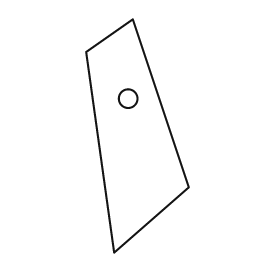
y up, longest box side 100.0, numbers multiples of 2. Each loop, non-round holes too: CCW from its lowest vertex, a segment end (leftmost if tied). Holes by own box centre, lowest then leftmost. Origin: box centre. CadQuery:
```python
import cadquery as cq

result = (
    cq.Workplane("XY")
    .moveTo(-10.0, -50.0)
    .lineTo(22.0, -22.0)
    .lineTo(-2.0, 50.0)
    .lineTo(-22.0, 36.0)
    .close()
    .moveTo(-4.0, 16.0)
    .circle(4.0)
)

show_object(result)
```